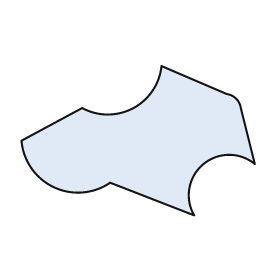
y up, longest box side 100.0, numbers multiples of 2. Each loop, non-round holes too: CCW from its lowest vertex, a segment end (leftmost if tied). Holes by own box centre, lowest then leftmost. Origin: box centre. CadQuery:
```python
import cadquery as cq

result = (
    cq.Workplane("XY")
    .moveTo(24.0, -32.0)
    .threePointArc((28.0, -10.0), (50.0, -10.0))
    .lineTo(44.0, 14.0)
    .threePointArc((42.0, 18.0), (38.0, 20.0))
    .lineTo(10.0, 32.0)
    .threePointArc((-2.0, 14.0), (-24.0, 14.0))
    .lineTo(-50.0, 0.0)
    .threePointArc((-36.0, -20.0), (-12.0, -18.0))
    .close()
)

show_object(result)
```